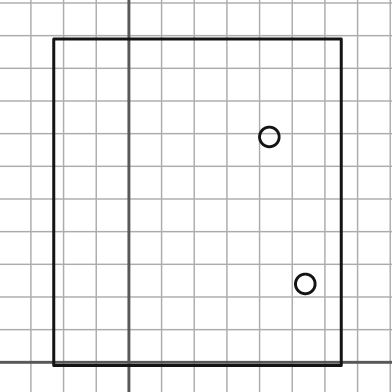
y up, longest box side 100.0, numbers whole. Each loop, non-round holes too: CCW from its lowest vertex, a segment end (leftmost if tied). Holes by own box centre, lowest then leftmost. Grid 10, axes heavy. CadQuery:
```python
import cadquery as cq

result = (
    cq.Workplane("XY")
    .moveTo(-23.0, -1.0)
    .lineTo(65.0, -1.0)
    .lineTo(65.0, 99.0)
    .lineTo(-23.0, 99.0)
    .close()
    .moveTo(54.0, 24.0)
    .circle(3.0)
    .moveTo(43.0, 69.0)
    .circle(3.0)
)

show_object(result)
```